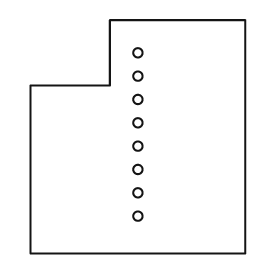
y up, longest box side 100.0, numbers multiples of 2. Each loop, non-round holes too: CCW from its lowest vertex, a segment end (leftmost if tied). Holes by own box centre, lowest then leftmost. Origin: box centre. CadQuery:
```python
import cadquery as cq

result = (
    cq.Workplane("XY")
    .moveTo(-46.0, -50.0)
    .lineTo(46.0, -50.0)
    .lineTo(46.0, 50.0)
    .lineTo(-12.0, 50.0)
    .lineTo(-12.0, 22.0)
    .lineTo(-46.0, 22.0)
    .close()
    .moveTo(0.0, -34.0)
    .circle(2.0)
    .moveTo(0.0, -24.0)
    .circle(2.0)
    .moveTo(0.0, -14.0)
    .circle(2.0)
    .moveTo(0.0, -4.0)
    .circle(2.0)
    .moveTo(0.0, 6.0)
    .circle(2.0)
    .moveTo(0.0, 16.0)
    .circle(2.0)
    .moveTo(0.0, 26.0)
    .circle(2.0)
    .moveTo(0.0, 36.0)
    .circle(2.0)
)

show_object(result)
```